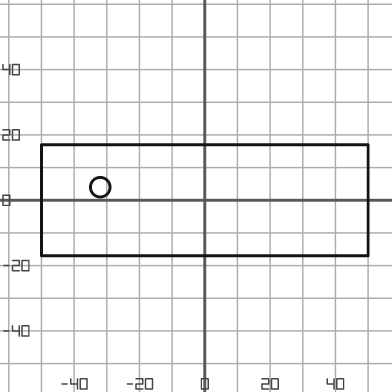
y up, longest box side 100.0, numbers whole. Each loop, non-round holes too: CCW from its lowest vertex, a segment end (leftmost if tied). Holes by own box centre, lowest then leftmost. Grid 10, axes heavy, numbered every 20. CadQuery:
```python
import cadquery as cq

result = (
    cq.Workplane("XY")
    .moveTo(-50.0, -17.0)
    .lineTo(50.0, -17.0)
    .lineTo(50.0, 17.0)
    .lineTo(-50.0, 17.0)
    .close()
    .moveTo(-32.0, 4.0)
    .circle(3.0)
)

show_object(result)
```